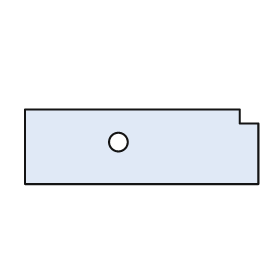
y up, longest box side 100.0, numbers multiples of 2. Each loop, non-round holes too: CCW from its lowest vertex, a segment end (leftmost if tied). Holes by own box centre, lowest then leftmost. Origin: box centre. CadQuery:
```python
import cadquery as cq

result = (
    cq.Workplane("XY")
    .moveTo(-50.0, -16.0)
    .lineTo(50.0, -16.0)
    .lineTo(50.0, 10.0)
    .lineTo(42.0, 10.0)
    .lineTo(42.0, 16.0)
    .lineTo(-50.0, 16.0)
    .close()
    .moveTo(-10.0, 2.0)
    .circle(4.0)
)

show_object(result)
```